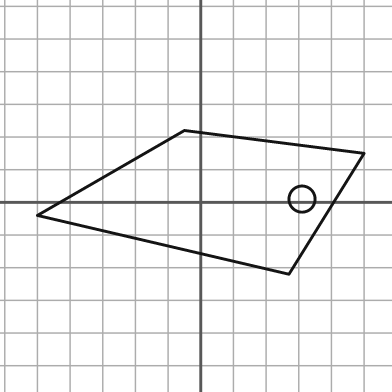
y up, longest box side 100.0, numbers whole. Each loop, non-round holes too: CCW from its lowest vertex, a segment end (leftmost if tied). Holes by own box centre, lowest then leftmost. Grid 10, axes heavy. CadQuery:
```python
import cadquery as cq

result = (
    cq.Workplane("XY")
    .moveTo(27.0, -22.0)
    .lineTo(50.0, 15.0)
    .lineTo(-5.0, 22.0)
    .lineTo(-50.0, -4.0)
    .close()
    .moveTo(31.0, 1.0)
    .circle(4.0)
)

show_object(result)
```